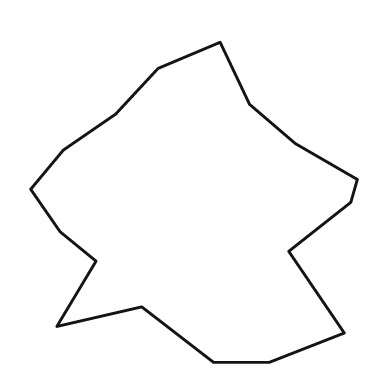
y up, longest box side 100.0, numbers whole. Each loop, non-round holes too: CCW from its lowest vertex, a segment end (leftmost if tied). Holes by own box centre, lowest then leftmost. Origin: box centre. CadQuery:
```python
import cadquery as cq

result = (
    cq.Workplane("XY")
    .moveTo(6.0, -49.0)
    .lineTo(23.0, -49.0)
    .lineTo(46.0, -40.0)
    .lineTo(29.0, -15.0)
    .lineTo(48.0, 0.0)
    .lineTo(50.0, 7.0)
    .lineTo(31.0, 18.0)
    .lineTo(17.0, 30.0)
    .lineTo(8.0, 49.0)
    .lineTo(-11.0, 41.0)
    .lineTo(-24.0, 27.0)
    .lineTo(-40.0, 16.0)
    .lineTo(-50.0, 4.0)
    .lineTo(-41.0, -9.0)
    .lineTo(-30.0, -18.0)
    .lineTo(-42.0, -38.0)
    .lineTo(-16.0, -32.0)
    .close()
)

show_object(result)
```